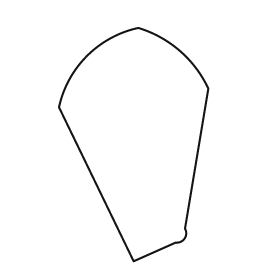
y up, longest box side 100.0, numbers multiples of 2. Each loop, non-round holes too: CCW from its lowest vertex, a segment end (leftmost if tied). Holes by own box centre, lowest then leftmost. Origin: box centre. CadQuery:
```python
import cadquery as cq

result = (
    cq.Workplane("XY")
    .moveTo(0.0, -50.0)
    .lineTo(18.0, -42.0)
    .threePointArc((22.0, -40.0), (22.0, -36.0))
    .lineTo(32.0, 24.0)
    .threePointArc((20.0, 40.0), (2.0, 50.0))
    .threePointArc((-20.0, 38.0), (-32.0, 16.0))
    .close()
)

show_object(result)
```